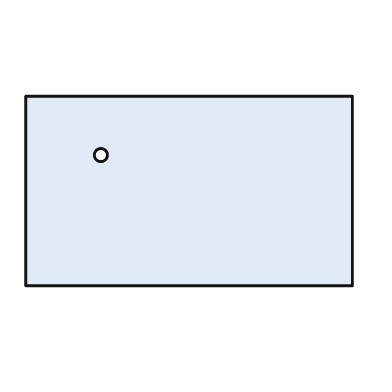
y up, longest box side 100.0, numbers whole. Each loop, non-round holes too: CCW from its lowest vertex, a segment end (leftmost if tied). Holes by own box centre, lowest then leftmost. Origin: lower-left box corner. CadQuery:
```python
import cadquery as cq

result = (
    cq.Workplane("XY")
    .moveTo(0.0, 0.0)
    .lineTo(100.0, 0.0)
    .lineTo(100.0, 58.0)
    .lineTo(0.0, 58.0)
    .close()
    .moveTo(23.0, 40.0)
    .circle(2.0)
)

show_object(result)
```